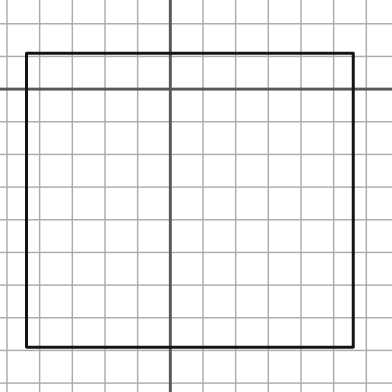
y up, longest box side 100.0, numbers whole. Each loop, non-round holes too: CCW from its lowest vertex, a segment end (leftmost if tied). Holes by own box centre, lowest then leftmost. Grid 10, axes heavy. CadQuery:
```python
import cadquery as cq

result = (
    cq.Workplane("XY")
    .moveTo(-44.0, -79.0)
    .lineTo(56.0, -79.0)
    .lineTo(56.0, 11.0)
    .lineTo(-44.0, 11.0)
    .close()
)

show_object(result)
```